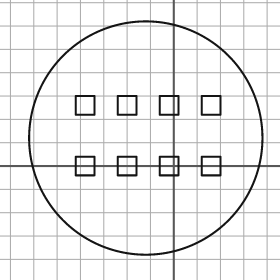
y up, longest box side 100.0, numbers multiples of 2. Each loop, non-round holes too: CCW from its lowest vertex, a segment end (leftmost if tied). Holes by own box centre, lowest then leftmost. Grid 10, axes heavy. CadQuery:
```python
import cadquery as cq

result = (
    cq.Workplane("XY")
    .moveTo(-12.0, 12.0)
    .circle(50.0)
    .moveTo(-42.0, -4.0)
    .lineTo(-34.0, -4.0)
    .lineTo(-34.0, 4.0)
    .lineTo(-42.0, 4.0)
    .close()
    .moveTo(-24.0, -4.0)
    .lineTo(-16.0, -4.0)
    .lineTo(-16.0, 4.0)
    .lineTo(-24.0, 4.0)
    .close()
    .moveTo(-6.0, -4.0)
    .lineTo(2.0, -4.0)
    .lineTo(2.0, 4.0)
    .lineTo(-6.0, 4.0)
    .close()
    .moveTo(12.0, -4.0)
    .lineTo(20.0, -4.0)
    .lineTo(20.0, 4.0)
    .lineTo(12.0, 4.0)
    .close()
    .moveTo(-42.0, 22.0)
    .lineTo(-34.0, 22.0)
    .lineTo(-34.0, 30.0)
    .lineTo(-42.0, 30.0)
    .close()
    .moveTo(-24.0, 22.0)
    .lineTo(-16.0, 22.0)
    .lineTo(-16.0, 30.0)
    .lineTo(-24.0, 30.0)
    .close()
    .moveTo(-6.0, 22.0)
    .lineTo(2.0, 22.0)
    .lineTo(2.0, 30.0)
    .lineTo(-6.0, 30.0)
    .close()
    .moveTo(12.0, 22.0)
    .lineTo(20.0, 22.0)
    .lineTo(20.0, 30.0)
    .lineTo(12.0, 30.0)
    .close()
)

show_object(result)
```